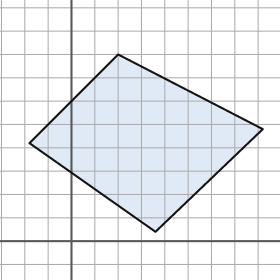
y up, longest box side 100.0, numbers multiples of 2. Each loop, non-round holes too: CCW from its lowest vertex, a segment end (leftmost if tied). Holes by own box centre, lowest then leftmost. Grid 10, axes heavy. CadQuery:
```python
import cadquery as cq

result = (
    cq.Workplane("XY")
    .moveTo(36.0, 4.0)
    .lineTo(82.0, 48.0)
    .lineTo(20.0, 80.0)
    .lineTo(-18.0, 42.0)
    .close()
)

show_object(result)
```